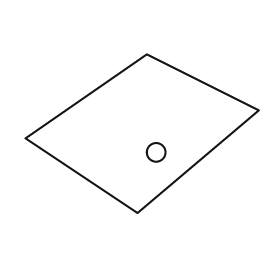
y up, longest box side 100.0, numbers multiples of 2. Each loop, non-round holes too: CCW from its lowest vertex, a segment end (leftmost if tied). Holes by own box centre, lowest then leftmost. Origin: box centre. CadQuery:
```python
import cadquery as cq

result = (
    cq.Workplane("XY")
    .moveTo(-2.0, -34.0)
    .lineTo(50.0, 10.0)
    .lineTo(2.0, 34.0)
    .lineTo(-50.0, -2.0)
    .close()
    .moveTo(6.0, -8.0)
    .circle(4.0)
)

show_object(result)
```